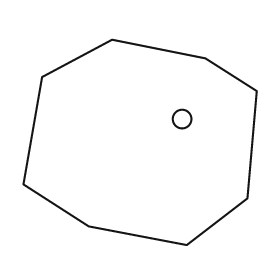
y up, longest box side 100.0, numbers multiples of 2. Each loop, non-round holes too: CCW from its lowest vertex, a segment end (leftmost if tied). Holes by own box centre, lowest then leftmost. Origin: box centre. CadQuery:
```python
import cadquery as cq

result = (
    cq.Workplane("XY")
    .moveTo(20.0, -44.0)
    .lineTo(46.0, -24.0)
    .lineTo(50.0, 22.0)
    .lineTo(28.0, 36.0)
    .lineTo(-12.0, 44.0)
    .lineTo(-42.0, 28.0)
    .lineTo(-50.0, -18.0)
    .lineTo(-22.0, -36.0)
    .close()
    .moveTo(18.0, 10.0)
    .circle(4.0)
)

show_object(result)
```